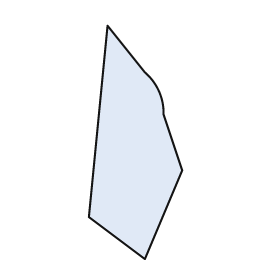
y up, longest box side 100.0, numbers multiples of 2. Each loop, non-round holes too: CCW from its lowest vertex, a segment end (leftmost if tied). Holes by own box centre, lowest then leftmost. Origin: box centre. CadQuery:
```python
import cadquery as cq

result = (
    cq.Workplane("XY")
    .moveTo(4.0, -50.0)
    .lineTo(20.0, -12.0)
    .lineTo(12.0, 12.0)
    .threePointArc((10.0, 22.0), (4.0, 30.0))
    .lineTo(-12.0, 50.0)
    .lineTo(-20.0, -32.0)
    .close()
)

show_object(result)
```